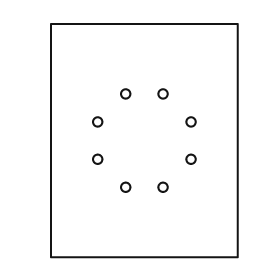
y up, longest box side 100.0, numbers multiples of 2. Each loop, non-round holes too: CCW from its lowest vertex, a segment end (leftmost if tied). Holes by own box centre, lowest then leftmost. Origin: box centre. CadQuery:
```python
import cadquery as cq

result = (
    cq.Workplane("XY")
    .moveTo(-40.0, -50.0)
    .lineTo(40.0, -50.0)
    .lineTo(40.0, 50.0)
    .lineTo(-40.0, 50.0)
    .close()
    .moveTo(-8.0, -20.0)
    .circle(2.0)
    .moveTo(8.0, -20.0)
    .circle(2.0)
    .moveTo(-20.0, -8.0)
    .circle(2.0)
    .moveTo(20.0, -8.0)
    .circle(2.0)
    .moveTo(-20.0, 8.0)
    .circle(2.0)
    .moveTo(20.0, 8.0)
    .circle(2.0)
    .moveTo(-8.0, 20.0)
    .circle(2.0)
    .moveTo(8.0, 20.0)
    .circle(2.0)
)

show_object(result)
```